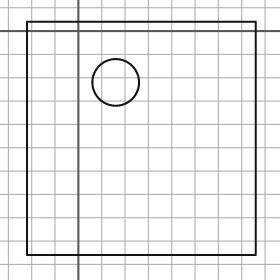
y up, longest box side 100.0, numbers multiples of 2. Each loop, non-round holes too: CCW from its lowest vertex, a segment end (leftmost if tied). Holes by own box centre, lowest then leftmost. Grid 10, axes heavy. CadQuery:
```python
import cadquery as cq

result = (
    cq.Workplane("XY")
    .moveTo(-22.0, -96.0)
    .lineTo(76.0, -96.0)
    .lineTo(76.0, 4.0)
    .lineTo(-22.0, 4.0)
    .close()
    .moveTo(16.0, -22.0)
    .circle(10.0)
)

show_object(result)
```